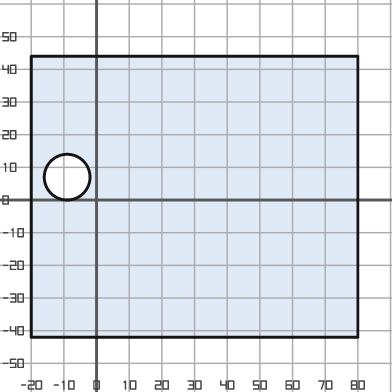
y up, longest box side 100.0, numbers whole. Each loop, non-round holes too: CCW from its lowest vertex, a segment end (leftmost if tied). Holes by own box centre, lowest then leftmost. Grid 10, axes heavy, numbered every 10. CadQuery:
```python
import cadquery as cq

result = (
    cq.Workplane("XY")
    .moveTo(-20.0, -42.0)
    .lineTo(80.0, -42.0)
    .lineTo(80.0, 44.0)
    .lineTo(-20.0, 44.0)
    .close()
    .moveTo(-9.0, 7.0)
    .circle(7.0)
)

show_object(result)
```